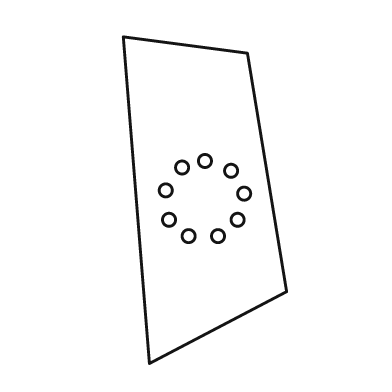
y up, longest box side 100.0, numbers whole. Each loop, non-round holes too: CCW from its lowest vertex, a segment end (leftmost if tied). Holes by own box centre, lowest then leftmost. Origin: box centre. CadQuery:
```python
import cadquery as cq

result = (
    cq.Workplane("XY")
    .moveTo(-17.0, -50.0)
    .lineTo(25.0, -28.0)
    .lineTo(13.0, 45.0)
    .lineTo(-25.0, 50.0)
    .close()
    .moveTo(-5.0, -11.0)
    .circle(2.0)
    .moveTo(4.0, -11.0)
    .circle(2.0)
    .moveTo(-11.0, -6.0)
    .circle(2.0)
    .moveTo(10.0, -6.0)
    .circle(2.0)
    .moveTo(12.0, 2.0)
    .circle(2.0)
    .moveTo(-12.0, 3.0)
    .circle(2.0)
    .moveTo(8.0, 9.0)
    .circle(2.0)
    .moveTo(-7.0, 10.0)
    .circle(2.0)
    .moveTo(0.0, 12.0)
    .circle(2.0)
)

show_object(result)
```